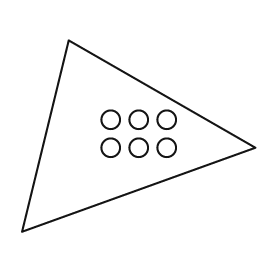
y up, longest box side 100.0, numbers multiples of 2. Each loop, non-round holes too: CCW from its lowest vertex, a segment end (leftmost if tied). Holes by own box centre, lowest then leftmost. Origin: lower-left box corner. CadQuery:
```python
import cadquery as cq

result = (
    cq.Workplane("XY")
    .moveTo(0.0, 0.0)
    .lineTo(100.0, 36.0)
    .lineTo(20.0, 82.0)
    .close()
    .moveTo(38.0, 36.0)
    .circle(4.0)
    .moveTo(50.0, 36.0)
    .circle(4.0)
    .moveTo(62.0, 36.0)
    .circle(4.0)
    .moveTo(38.0, 48.0)
    .circle(4.0)
    .moveTo(50.0, 48.0)
    .circle(4.0)
    .moveTo(62.0, 48.0)
    .circle(4.0)
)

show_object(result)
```